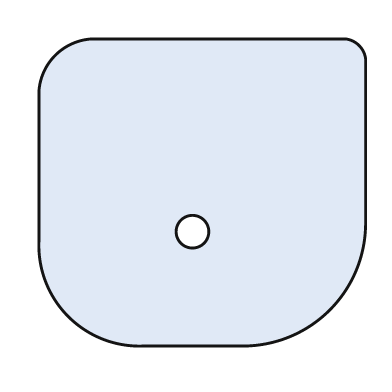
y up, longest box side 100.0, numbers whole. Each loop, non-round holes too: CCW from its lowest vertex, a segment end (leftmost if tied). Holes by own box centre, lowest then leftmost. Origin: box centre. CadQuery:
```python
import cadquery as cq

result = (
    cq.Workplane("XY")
    .moveTo(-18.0, -47.0)
    .lineTo(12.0, -47.0)
    .threePointArc((39.0, -36.0), (50.0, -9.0))
    .lineTo(50.0, 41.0)
    .threePointArc((48.0, 45.0), (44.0, 47.0))
    .lineTo(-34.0, 47.0)
    .threePointArc((-45.0, 42.0), (-50.0, 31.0))
    .lineTo(-50.0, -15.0)
    .threePointArc((-41.0, -38.0), (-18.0, -47.0))
    .close()
    .moveTo(-3.0, -12.0)
    .circle(5.0)
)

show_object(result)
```